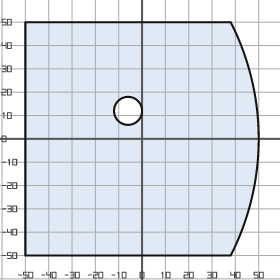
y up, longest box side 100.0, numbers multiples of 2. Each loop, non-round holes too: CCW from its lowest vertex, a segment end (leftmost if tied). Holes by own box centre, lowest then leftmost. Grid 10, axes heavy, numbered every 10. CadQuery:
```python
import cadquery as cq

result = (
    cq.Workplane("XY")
    .moveTo(-50.0, -50.0)
    .lineTo(38.0, -50.0)
    .threePointArc((50.0, 0.0), (38.0, 50.0))
    .lineTo(-50.0, 50.0)
    .close()
    .moveTo(-6.0, 12.0)
    .circle(6.0)
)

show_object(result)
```